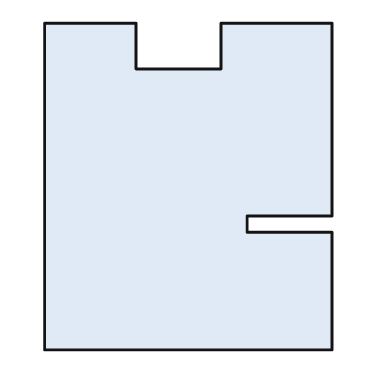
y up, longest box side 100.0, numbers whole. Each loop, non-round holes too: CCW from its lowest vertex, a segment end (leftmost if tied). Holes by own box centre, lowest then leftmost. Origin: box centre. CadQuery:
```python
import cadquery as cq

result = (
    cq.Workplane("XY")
    .moveTo(-44.0, -50.0)
    .lineTo(44.0, -50.0)
    .lineTo(44.0, -14.0)
    .lineTo(18.0, -14.0)
    .lineTo(18.0, -9.0)
    .lineTo(44.0, -9.0)
    .lineTo(44.0, 50.0)
    .lineTo(10.0, 50.0)
    .lineTo(10.0, 36.0)
    .lineTo(-16.0, 36.0)
    .lineTo(-16.0, 50.0)
    .lineTo(-44.0, 50.0)
    .close()
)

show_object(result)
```